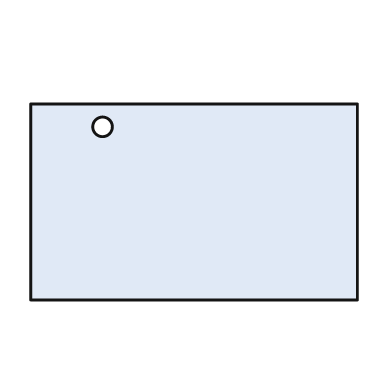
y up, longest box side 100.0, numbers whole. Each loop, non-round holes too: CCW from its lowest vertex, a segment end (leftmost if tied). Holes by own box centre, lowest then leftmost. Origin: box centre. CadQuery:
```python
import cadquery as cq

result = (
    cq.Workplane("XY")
    .moveTo(-50.0, -30.0)
    .lineTo(50.0, -30.0)
    .lineTo(50.0, 30.0)
    .lineTo(-50.0, 30.0)
    .close()
    .moveTo(-28.0, 23.0)
    .circle(3.0)
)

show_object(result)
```